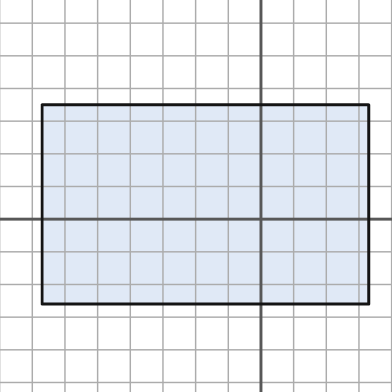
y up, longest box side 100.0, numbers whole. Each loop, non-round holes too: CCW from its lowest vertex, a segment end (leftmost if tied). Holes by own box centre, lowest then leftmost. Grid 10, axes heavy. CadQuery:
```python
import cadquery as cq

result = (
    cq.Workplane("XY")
    .moveTo(-67.0, -26.0)
    .lineTo(33.0, -26.0)
    .lineTo(33.0, 35.0)
    .lineTo(-67.0, 35.0)
    .close()
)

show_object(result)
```